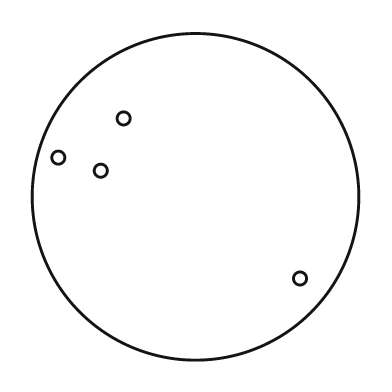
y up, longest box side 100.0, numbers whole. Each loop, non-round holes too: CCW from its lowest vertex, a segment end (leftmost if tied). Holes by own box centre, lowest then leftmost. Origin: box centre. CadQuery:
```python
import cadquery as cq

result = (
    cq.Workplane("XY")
    .moveTo(0.0, 0.0)
    .circle(50.0)
    .moveTo(32.0, -25.0)
    .circle(2.0)
    .moveTo(-29.0, 8.0)
    .circle(2.0)
    .moveTo(-42.0, 12.0)
    .circle(2.0)
    .moveTo(-22.0, 24.0)
    .circle(2.0)
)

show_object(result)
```